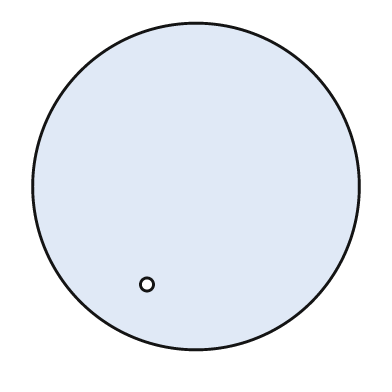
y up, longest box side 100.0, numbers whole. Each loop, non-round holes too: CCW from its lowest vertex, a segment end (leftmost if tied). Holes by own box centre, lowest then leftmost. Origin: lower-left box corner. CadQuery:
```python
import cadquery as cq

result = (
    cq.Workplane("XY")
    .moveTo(50.0, 50.0)
    .circle(50.0)
    .moveTo(35.0, 20.0)
    .circle(2.0)
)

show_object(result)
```